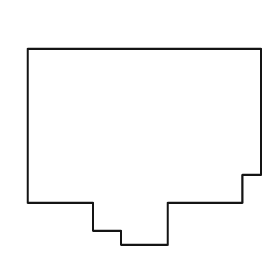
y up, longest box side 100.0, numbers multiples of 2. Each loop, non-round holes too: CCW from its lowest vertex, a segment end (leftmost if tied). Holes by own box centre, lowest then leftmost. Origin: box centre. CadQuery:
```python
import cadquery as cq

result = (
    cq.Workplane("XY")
    .moveTo(-10.0, -42.0)
    .lineTo(10.0, -42.0)
    .lineTo(10.0, -24.0)
    .lineTo(42.0, -24.0)
    .lineTo(42.0, -12.0)
    .lineTo(50.0, -12.0)
    .lineTo(50.0, 42.0)
    .lineTo(-50.0, 42.0)
    .lineTo(-50.0, -24.0)
    .lineTo(-22.0, -24.0)
    .lineTo(-22.0, -36.0)
    .lineTo(-10.0, -36.0)
    .close()
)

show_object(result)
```